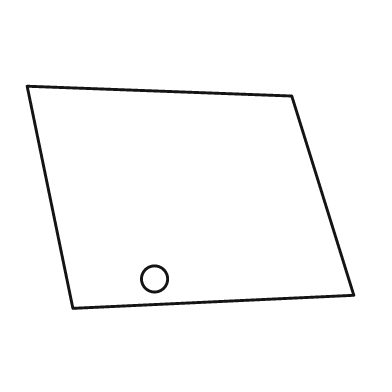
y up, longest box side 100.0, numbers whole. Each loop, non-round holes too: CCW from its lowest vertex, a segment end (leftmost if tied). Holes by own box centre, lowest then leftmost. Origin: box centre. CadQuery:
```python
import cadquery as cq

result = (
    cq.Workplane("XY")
    .moveTo(-36.0, -34.0)
    .lineTo(50.0, -30.0)
    .lineTo(31.0, 31.0)
    .lineTo(-50.0, 34.0)
    .close()
    .moveTo(-11.0, -25.0)
    .circle(4.0)
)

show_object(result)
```